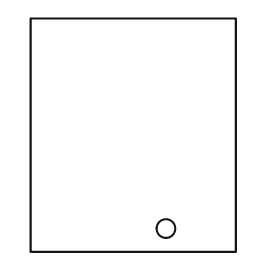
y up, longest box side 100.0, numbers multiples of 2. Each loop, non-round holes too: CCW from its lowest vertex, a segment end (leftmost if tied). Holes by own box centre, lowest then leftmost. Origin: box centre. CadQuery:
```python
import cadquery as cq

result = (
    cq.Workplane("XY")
    .moveTo(-44.0, -50.0)
    .lineTo(44.0, -50.0)
    .lineTo(44.0, 50.0)
    .lineTo(-44.0, 50.0)
    .close()
    .moveTo(14.0, -40.0)
    .circle(4.0)
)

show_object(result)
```